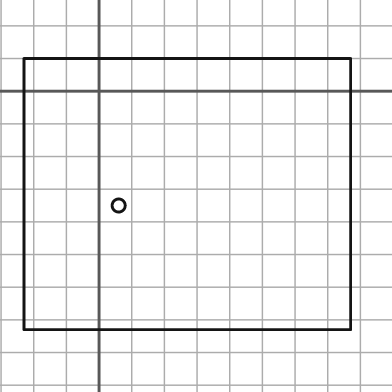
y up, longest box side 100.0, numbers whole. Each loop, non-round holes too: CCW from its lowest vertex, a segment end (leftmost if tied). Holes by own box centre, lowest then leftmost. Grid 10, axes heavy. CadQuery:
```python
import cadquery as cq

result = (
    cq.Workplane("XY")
    .moveTo(-23.0, -73.0)
    .lineTo(77.0, -73.0)
    .lineTo(77.0, 10.0)
    .lineTo(-23.0, 10.0)
    .close()
    .moveTo(6.0, -35.0)
    .circle(2.0)
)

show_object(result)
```